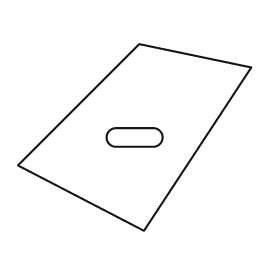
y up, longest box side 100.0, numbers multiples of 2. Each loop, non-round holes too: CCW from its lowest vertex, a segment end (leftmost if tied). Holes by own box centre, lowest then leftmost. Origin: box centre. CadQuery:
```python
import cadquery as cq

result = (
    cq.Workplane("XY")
    .moveTo(4.0, -40.0)
    .lineTo(50.0, 30.0)
    .lineTo(2.0, 40.0)
    .lineTo(-50.0, -12.0)
    .close()
    .moveTo(-8.0, -4.0)
    .lineTo(8.0, -4.0)
    .threePointArc((12.0, 0.0), (8.0, 4.0))
    .lineTo(-8.0, 4.0)
    .threePointArc((-12.0, 0.0), (-8.0, -4.0))
    .close()
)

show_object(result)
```